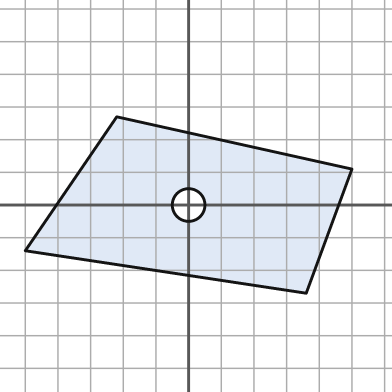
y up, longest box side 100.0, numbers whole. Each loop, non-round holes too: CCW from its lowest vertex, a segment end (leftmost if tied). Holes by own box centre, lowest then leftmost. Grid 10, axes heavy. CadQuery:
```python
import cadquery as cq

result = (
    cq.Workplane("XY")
    .moveTo(36.0, -27.0)
    .lineTo(50.0, 11.0)
    .lineTo(-22.0, 27.0)
    .lineTo(-50.0, -14.0)
    .close()
    .moveTo(0.0, 0.0)
    .circle(5.0)
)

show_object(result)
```